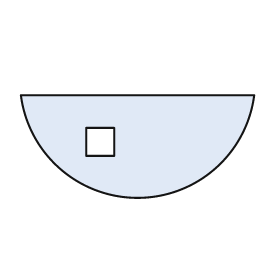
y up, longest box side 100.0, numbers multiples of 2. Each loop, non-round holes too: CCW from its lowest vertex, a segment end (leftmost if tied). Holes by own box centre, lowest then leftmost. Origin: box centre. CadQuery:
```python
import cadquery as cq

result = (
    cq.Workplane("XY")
    .moveTo(-50.0, 22.0)
    .threePointArc((0.0, -22.0), (50.0, 22.0))
    .close()
    .moveTo(-22.0, -4.0)
    .lineTo(-10.0, -4.0)
    .lineTo(-10.0, 8.0)
    .lineTo(-22.0, 8.0)
    .close()
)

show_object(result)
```